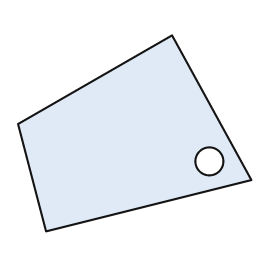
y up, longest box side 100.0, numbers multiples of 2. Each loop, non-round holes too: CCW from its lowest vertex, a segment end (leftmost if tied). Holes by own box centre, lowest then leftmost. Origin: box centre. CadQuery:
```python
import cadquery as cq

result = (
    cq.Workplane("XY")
    .moveTo(-38.0, -42.0)
    .lineTo(50.0, -20.0)
    .lineTo(16.0, 42.0)
    .lineTo(-50.0, 4.0)
    .close()
    .moveTo(32.0, -12.0)
    .circle(6.0)
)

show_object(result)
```